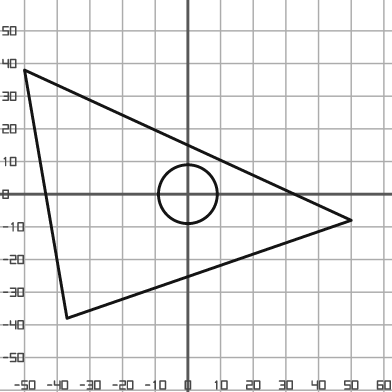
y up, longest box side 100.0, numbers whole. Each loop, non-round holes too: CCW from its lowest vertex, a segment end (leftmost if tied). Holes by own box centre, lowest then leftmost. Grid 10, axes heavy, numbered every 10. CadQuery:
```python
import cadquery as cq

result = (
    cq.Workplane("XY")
    .moveTo(-37.0, -38.0)
    .lineTo(50.0, -8.0)
    .lineTo(-50.0, 38.0)
    .close()
    .moveTo(0.0, 0.0)
    .circle(9.0)
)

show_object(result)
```